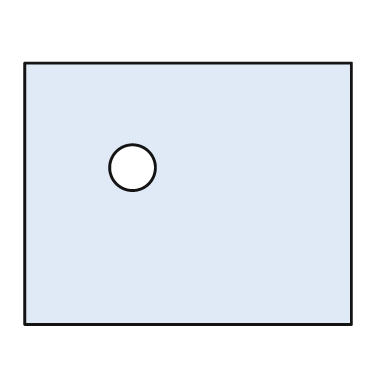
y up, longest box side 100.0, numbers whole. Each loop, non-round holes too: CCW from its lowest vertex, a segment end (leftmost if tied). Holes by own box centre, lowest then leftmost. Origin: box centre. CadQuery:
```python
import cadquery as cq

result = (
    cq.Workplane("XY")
    .moveTo(-50.0, -40.0)
    .lineTo(50.0, -40.0)
    .lineTo(50.0, 40.0)
    .lineTo(-50.0, 40.0)
    .close()
    .moveTo(-17.0, 8.0)
    .circle(7.0)
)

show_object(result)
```